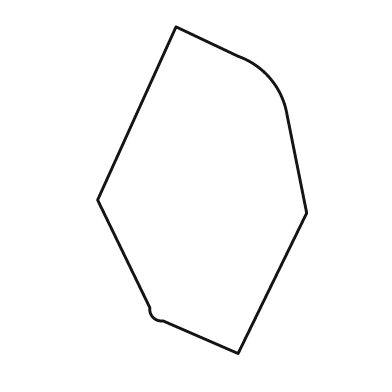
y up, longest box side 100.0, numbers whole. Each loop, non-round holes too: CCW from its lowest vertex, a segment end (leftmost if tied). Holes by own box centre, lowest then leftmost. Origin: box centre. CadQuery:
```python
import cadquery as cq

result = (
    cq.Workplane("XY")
    .moveTo(11.0, -50.0)
    .lineTo(32.0, -7.0)
    .lineTo(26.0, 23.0)
    .threePointArc((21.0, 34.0), (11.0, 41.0))
    .lineTo(-8.0, 50.0)
    .lineTo(-32.0, -3.0)
    .lineTo(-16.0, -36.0)
    .threePointArc((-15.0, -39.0), (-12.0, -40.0))
    .close()
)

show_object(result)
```